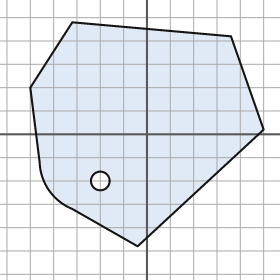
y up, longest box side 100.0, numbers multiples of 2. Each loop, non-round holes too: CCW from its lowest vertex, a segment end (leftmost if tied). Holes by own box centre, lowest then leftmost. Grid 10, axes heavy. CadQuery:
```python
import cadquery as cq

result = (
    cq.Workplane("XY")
    .moveTo(-4.0, -48.0)
    .lineTo(50.0, 2.0)
    .lineTo(36.0, 42.0)
    .lineTo(-32.0, 48.0)
    .lineTo(-50.0, 20.0)
    .lineTo(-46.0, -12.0)
    .threePointArc((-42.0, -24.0), (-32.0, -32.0))
    .close()
    .moveTo(-20.0, -20.0)
    .circle(4.0)
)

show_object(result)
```